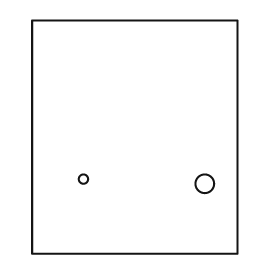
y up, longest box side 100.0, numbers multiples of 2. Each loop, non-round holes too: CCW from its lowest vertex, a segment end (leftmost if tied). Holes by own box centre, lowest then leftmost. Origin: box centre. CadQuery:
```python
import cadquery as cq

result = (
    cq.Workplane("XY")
    .moveTo(-44.0, -50.0)
    .lineTo(44.0, -50.0)
    .lineTo(44.0, 50.0)
    .lineTo(-44.0, 50.0)
    .close()
    .moveTo(30.0, -20.0)
    .circle(4.0)
    .moveTo(-22.0, -18.0)
    .circle(2.0)
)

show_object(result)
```